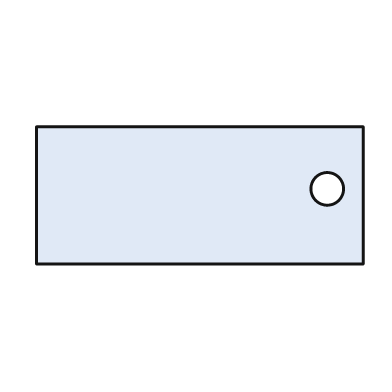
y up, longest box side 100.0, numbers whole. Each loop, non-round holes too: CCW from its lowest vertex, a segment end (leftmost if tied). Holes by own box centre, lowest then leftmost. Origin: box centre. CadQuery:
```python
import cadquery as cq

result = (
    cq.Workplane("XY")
    .moveTo(-50.0, -21.0)
    .lineTo(50.0, -21.0)
    .lineTo(50.0, 21.0)
    .lineTo(-50.0, 21.0)
    .close()
    .moveTo(39.0, 2.0)
    .circle(5.0)
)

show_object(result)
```